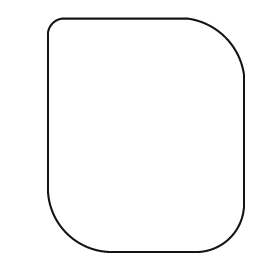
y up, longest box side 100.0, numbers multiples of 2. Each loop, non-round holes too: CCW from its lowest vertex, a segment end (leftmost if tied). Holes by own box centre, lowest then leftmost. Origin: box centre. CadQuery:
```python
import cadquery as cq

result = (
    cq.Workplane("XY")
    .moveTo(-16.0, -50.0)
    .lineTo(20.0, -50.0)
    .threePointArc((36.0, -44.0), (42.0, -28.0))
    .lineTo(42.0, 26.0)
    .threePointArc((34.0, 42.0), (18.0, 50.0))
    .lineTo(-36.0, 50.0)
    .threePointArc((-40.0, 48.0), (-42.0, 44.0))
    .lineTo(-42.0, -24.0)
    .threePointArc((-34.0, -42.0), (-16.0, -50.0))
    .close()
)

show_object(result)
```